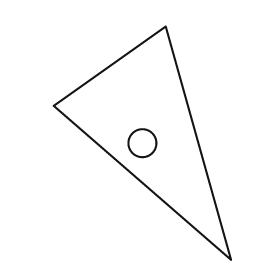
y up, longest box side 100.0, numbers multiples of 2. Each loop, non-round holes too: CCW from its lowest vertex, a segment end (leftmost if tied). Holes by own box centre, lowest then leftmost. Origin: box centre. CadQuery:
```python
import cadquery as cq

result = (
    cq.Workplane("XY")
    .moveTo(38.0, -50.0)
    .lineTo(10.0, 50.0)
    .lineTo(-38.0, 16.0)
    .close()
    .moveTo(0.0, 0.0)
    .circle(6.0)
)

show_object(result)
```